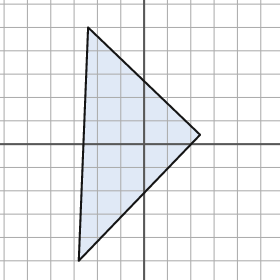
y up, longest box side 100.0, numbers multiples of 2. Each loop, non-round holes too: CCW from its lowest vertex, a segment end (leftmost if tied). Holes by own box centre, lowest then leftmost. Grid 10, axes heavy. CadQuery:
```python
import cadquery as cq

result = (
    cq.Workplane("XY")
    .moveTo(-28.0, -50.0)
    .lineTo(24.0, 4.0)
    .lineTo(-24.0, 50.0)
    .close()
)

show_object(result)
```